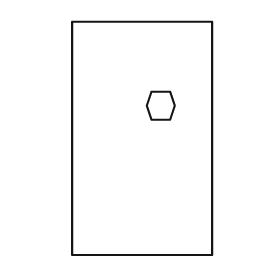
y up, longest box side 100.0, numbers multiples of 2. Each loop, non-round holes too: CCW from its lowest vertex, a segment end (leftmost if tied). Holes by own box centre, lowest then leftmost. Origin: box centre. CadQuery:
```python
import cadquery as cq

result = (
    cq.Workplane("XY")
    .moveTo(-30.0, -50.0)
    .lineTo(30.0, -50.0)
    .lineTo(30.0, 50.0)
    .lineTo(-30.0, 50.0)
    .close()
    .moveTo(4.0, 8.0)
    .lineTo(12.0, 8.0)
    .lineTo(14.0, 14.0)
    .lineTo(12.0, 20.0)
    .lineTo(4.0, 20.0)
    .lineTo(2.0, 14.0)
    .close()
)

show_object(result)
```